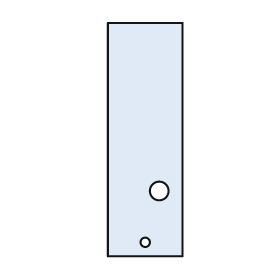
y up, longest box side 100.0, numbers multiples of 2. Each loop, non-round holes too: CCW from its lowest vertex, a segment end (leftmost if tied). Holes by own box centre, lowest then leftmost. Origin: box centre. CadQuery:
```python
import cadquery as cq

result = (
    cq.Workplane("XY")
    .moveTo(-16.0, -50.0)
    .lineTo(16.0, -50.0)
    .lineTo(16.0, 50.0)
    .lineTo(-16.0, 50.0)
    .close()
    .moveTo(0.0, -44.0)
    .circle(2.0)
    .moveTo(6.0, -22.0)
    .circle(4.0)
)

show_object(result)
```